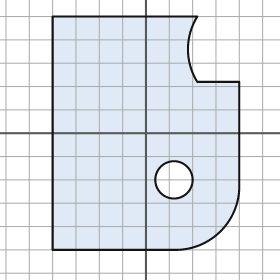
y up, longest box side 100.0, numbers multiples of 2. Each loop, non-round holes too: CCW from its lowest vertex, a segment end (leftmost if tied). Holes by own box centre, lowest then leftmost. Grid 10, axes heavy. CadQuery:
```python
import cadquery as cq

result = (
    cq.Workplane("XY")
    .moveTo(-40.0, -50.0)
    .lineTo(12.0, -50.0)
    .threePointArc((32.0, -42.0), (40.0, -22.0))
    .lineTo(40.0, 22.0)
    .lineTo(22.0, 22.0)
    .threePointArc((18.0, 36.0), (22.0, 50.0))
    .lineTo(-40.0, 50.0)
    .close()
    .moveTo(12.0, -20.0)
    .circle(8.0)
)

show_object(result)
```